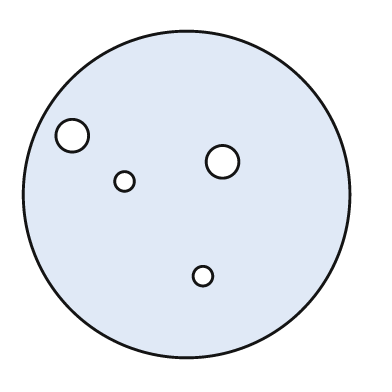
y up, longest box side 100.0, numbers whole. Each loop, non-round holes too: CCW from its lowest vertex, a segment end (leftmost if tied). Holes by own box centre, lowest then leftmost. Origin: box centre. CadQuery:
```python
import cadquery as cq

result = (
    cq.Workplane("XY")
    .moveTo(0.0, 0.0)
    .circle(50.0)
    .moveTo(5.0, -25.0)
    .circle(3.0)
    .moveTo(-19.0, 4.0)
    .circle(3.0)
    .moveTo(11.0, 10.0)
    .circle(5.0)
    .moveTo(-35.0, 18.0)
    .circle(5.0)
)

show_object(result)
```